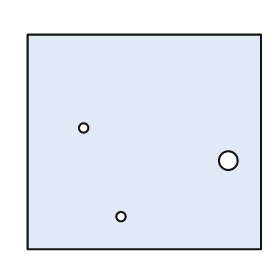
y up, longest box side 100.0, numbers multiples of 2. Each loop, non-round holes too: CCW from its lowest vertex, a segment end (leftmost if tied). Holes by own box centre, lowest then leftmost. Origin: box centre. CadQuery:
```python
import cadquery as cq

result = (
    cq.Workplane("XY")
    .moveTo(-50.0, -46.0)
    .lineTo(50.0, -46.0)
    .lineTo(50.0, 46.0)
    .lineTo(-50.0, 46.0)
    .close()
    .moveTo(-10.0, -32.0)
    .circle(2.0)
    .moveTo(36.0, -8.0)
    .circle(4.0)
    .moveTo(-26.0, 6.0)
    .circle(2.0)
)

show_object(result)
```